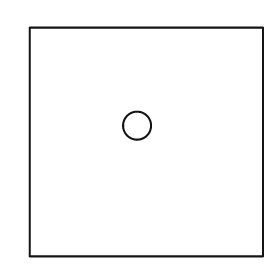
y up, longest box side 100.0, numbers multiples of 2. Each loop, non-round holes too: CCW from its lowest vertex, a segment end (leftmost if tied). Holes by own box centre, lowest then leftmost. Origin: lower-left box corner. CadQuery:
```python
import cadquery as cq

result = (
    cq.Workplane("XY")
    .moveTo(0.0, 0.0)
    .lineTo(100.0, 0.0)
    .lineTo(100.0, 98.0)
    .lineTo(0.0, 98.0)
    .close()
    .moveTo(46.0, 56.0)
    .circle(6.0)
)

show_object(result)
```